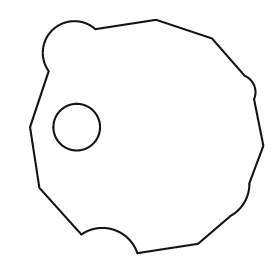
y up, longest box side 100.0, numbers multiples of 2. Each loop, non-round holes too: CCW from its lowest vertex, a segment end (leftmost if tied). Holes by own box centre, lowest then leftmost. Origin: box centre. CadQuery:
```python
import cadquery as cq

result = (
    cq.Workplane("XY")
    .moveTo(-4.0, -50.0)
    .lineTo(22.0, -46.0)
    .lineTo(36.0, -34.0)
    .threePointArc((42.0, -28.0), (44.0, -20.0))
    .lineTo(50.0, -4.0)
    .lineTo(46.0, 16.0)
    .threePointArc((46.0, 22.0), (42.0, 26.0))
    .lineTo(28.0, 42.0)
    .lineTo(4.0, 50.0)
    .lineTo(-22.0, 46.0)
    .threePointArc((-40.0, 46.0), (-42.0, 28.0))
    .lineTo(-50.0, 4.0)
    .lineTo(-46.0, -22.0)
    .lineTo(-28.0, -42.0)
    .threePointArc((-14.0, -40.0), (-4.0, -50.0))
    .close()
    .moveTo(-30.0, 4.0)
    .circle(10.0)
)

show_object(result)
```